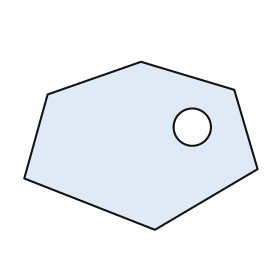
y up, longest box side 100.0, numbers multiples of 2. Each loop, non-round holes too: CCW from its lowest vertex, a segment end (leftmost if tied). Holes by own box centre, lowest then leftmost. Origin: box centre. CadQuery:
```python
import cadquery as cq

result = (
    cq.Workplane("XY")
    .moveTo(6.0, -36.0)
    .lineTo(50.0, -10.0)
    .lineTo(40.0, 24.0)
    .lineTo(0.0, 36.0)
    .lineTo(-40.0, 22.0)
    .lineTo(-50.0, -14.0)
    .close()
    .moveTo(22.0, 8.0)
    .circle(8.0)
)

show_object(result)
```